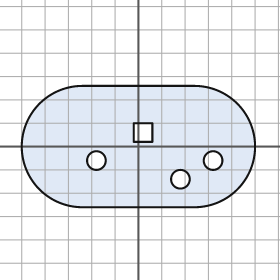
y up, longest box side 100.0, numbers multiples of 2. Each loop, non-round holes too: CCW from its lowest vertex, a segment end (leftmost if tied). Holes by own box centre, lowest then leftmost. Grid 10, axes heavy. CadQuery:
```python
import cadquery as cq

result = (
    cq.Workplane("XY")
    .moveTo(-24.0, -26.0)
    .lineTo(24.0, -26.0)
    .threePointArc((50.0, 0.0), (24.0, 26.0))
    .lineTo(-24.0, 26.0)
    .threePointArc((-50.0, 0.0), (-24.0, -26.0))
    .close()
    .moveTo(18.0, -14.0)
    .circle(4.0)
    .moveTo(-18.0, -6.0)
    .circle(4.0)
    .moveTo(32.0, -6.0)
    .circle(4.0)
    .moveTo(-2.0, 2.0)
    .lineTo(6.0, 2.0)
    .lineTo(6.0, 10.0)
    .lineTo(-2.0, 10.0)
    .close()
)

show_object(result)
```